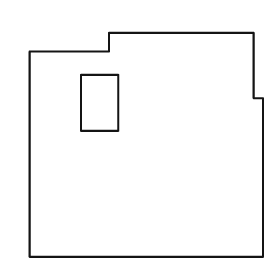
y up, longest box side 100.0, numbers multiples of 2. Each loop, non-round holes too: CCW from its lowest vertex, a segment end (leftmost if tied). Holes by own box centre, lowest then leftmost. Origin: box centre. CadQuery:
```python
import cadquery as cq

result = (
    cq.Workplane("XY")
    .moveTo(-50.0, -48.0)
    .lineTo(50.0, -48.0)
    .lineTo(50.0, 20.0)
    .lineTo(46.0, 20.0)
    .lineTo(46.0, 48.0)
    .lineTo(-16.0, 48.0)
    .lineTo(-16.0, 40.0)
    .lineTo(-50.0, 40.0)
    .close()
    .moveTo(-28.0, 6.0)
    .lineTo(-12.0, 6.0)
    .lineTo(-12.0, 30.0)
    .lineTo(-28.0, 30.0)
    .close()
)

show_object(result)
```